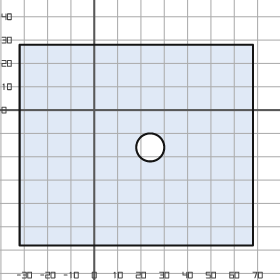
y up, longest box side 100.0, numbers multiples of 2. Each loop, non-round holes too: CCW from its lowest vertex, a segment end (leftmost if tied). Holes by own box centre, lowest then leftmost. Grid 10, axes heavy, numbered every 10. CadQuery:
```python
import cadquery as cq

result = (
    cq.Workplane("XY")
    .moveTo(-32.0, -58.0)
    .lineTo(68.0, -58.0)
    .lineTo(68.0, 28.0)
    .lineTo(-32.0, 28.0)
    .close()
    .moveTo(24.0, -16.0)
    .circle(6.0)
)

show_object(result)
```